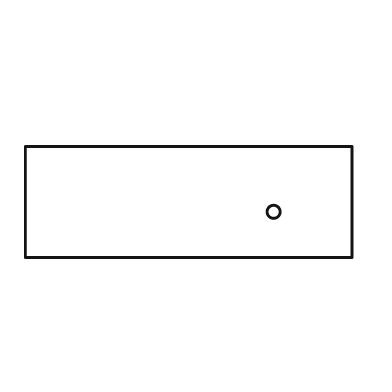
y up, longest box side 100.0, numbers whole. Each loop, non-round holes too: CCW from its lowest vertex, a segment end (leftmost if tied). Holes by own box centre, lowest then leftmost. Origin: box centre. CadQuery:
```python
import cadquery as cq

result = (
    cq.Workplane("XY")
    .moveTo(-50.0, -17.0)
    .lineTo(50.0, -17.0)
    .lineTo(50.0, 17.0)
    .lineTo(-50.0, 17.0)
    .close()
    .moveTo(26.0, -3.0)
    .circle(2.0)
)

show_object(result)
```